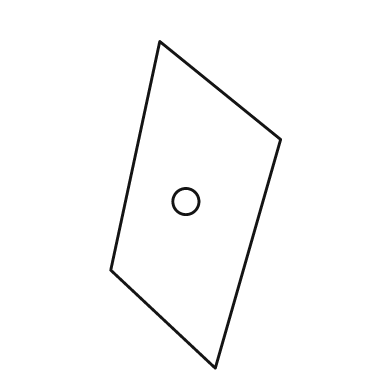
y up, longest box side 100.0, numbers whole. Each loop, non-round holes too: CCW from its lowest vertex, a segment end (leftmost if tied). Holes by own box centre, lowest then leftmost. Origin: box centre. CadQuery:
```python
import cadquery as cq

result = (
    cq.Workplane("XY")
    .moveTo(6.0, -50.0)
    .lineTo(26.0, 20.0)
    .lineTo(-11.0, 50.0)
    .lineTo(-26.0, -20.0)
    .close()
    .moveTo(-3.0, 1.0)
    .circle(4.0)
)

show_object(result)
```